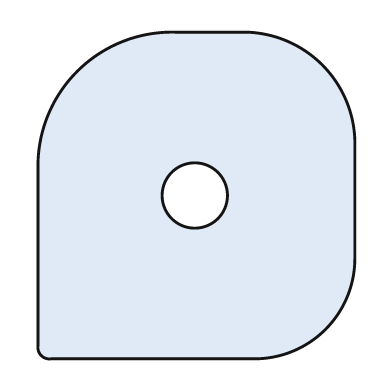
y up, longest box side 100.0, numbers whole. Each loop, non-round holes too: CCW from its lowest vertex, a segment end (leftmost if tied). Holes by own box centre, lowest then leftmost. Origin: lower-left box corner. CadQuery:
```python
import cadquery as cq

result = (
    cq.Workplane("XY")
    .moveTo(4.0, 0.0)
    .lineTo(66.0, 0.0)
    .threePointArc((88.0, 9.0), (97.0, 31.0))
    .lineTo(97.0, 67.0)
    .threePointArc((87.0, 90.0), (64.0, 100.0))
    .lineTo(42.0, 100.0)
    .threePointArc((12.0, 88.0), (0.0, 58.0))
    .lineTo(0.0, 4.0)
    .threePointArc((1.0, 1.0), (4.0, 0.0))
    .close()
    .moveTo(48.0, 50.0)
    .circle(10.0)
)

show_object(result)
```